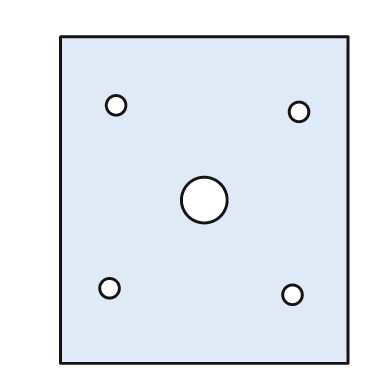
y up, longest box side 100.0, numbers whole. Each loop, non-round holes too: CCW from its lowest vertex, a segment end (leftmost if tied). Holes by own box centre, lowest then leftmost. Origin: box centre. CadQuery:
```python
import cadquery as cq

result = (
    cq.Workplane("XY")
    .moveTo(-44.0, -50.0)
    .lineTo(44.0, -50.0)
    .lineTo(44.0, 50.0)
    .lineTo(-44.0, 50.0)
    .close()
    .moveTo(27.0, -29.0)
    .circle(3.0)
    .moveTo(-29.0, -27.0)
    .circle(3.0)
    .moveTo(0.0, 0.0)
    .circle(7.0)
    .moveTo(29.0, 27.0)
    .circle(3.0)
    .moveTo(-27.0, 29.0)
    .circle(3.0)
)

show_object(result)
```